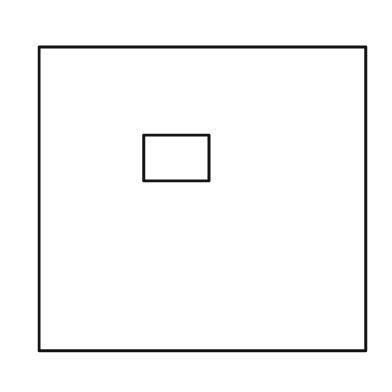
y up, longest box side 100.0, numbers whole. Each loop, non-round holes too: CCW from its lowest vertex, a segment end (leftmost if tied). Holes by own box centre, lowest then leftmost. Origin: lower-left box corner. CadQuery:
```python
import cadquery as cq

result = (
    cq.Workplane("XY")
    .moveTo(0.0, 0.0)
    .lineTo(100.0, 0.0)
    .lineTo(100.0, 93.0)
    .lineTo(0.0, 93.0)
    .close()
    .moveTo(32.0, 52.0)
    .lineTo(52.0, 52.0)
    .lineTo(52.0, 66.0)
    .lineTo(32.0, 66.0)
    .close()
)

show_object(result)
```